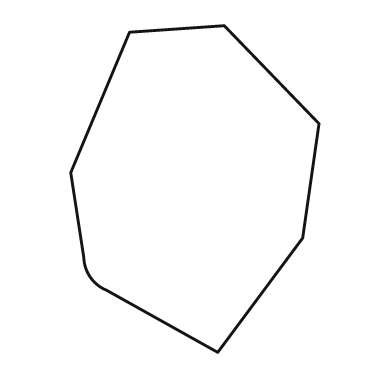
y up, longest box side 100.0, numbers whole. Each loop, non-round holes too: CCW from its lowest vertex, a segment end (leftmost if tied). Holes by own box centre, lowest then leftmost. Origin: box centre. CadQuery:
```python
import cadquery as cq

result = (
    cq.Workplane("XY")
    .moveTo(7.0, -50.0)
    .lineTo(33.0, -15.0)
    .lineTo(38.0, 20.0)
    .lineTo(9.0, 50.0)
    .lineTo(-20.0, 48.0)
    .lineTo(-38.0, 5.0)
    .lineTo(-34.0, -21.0)
    .threePointArc((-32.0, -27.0), (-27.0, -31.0))
    .close()
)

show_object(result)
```